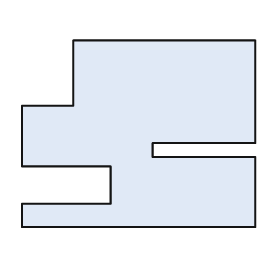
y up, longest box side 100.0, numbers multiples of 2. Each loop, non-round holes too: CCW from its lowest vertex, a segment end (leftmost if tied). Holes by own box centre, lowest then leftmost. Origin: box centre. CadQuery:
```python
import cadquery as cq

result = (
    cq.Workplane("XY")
    .moveTo(-50.0, -40.0)
    .lineTo(50.0, -40.0)
    .lineTo(50.0, -10.0)
    .lineTo(6.0, -10.0)
    .lineTo(6.0, -4.0)
    .lineTo(50.0, -4.0)
    .lineTo(50.0, 40.0)
    .lineTo(-28.0, 40.0)
    .lineTo(-28.0, 12.0)
    .lineTo(-50.0, 12.0)
    .lineTo(-50.0, -14.0)
    .lineTo(-12.0, -14.0)
    .lineTo(-12.0, -30.0)
    .lineTo(-50.0, -30.0)
    .close()
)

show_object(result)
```